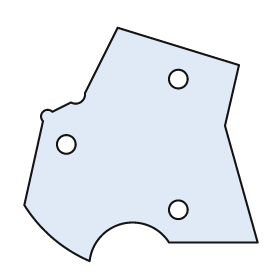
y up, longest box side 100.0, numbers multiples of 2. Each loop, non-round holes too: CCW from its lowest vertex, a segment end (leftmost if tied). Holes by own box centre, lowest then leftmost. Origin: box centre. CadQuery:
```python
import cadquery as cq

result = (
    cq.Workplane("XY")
    .moveTo(-22.0, -50.0)
    .threePointArc((-8.0, -34.0), (12.0, -42.0))
    .lineTo(50.0, -42.0)
    .lineTo(36.0, 8.0)
    .lineTo(42.0, 34.0)
    .lineTo(-10.0, 50.0)
    .lineTo(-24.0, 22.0)
    .threePointArc((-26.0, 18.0), (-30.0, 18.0))
    .lineTo(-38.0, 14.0)
    .threePointArc((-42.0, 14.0), (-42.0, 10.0))
    .lineTo(-50.0, -26.0)
    .threePointArc((-38.0, -40.0), (-22.0, -50.0))
    .close()
    .moveTo(16.0, -28.0)
    .circle(4.0)
    .moveTo(-32.0, 0.0)
    .circle(4.0)
    .moveTo(16.0, 28.0)
    .circle(4.0)
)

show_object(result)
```